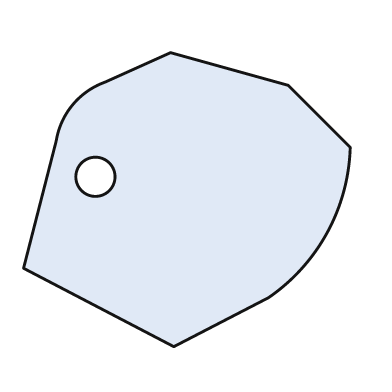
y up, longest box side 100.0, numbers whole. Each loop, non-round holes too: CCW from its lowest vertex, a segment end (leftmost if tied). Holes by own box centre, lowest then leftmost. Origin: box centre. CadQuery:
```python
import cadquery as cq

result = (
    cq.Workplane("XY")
    .moveTo(-4.0, -45.0)
    .lineTo(25.0, -30.0)
    .threePointArc((43.0, -10.0), (50.0, 16.0))
    .lineTo(31.0, 35.0)
    .lineTo(-5.0, 45.0)
    .lineTo(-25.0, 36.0)
    .threePointArc((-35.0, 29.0), (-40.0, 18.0))
    .lineTo(-50.0, -21.0)
    .close()
    .moveTo(-28.0, 7.0)
    .circle(6.0)
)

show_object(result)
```